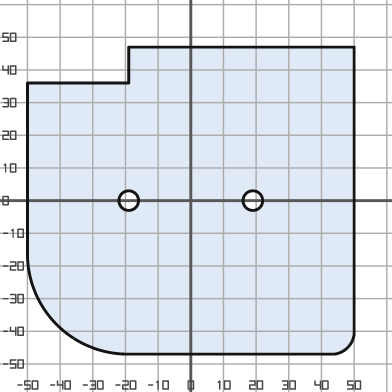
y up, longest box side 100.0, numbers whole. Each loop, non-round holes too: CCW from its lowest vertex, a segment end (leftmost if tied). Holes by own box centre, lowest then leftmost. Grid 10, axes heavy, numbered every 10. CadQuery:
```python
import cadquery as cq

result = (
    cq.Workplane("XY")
    .moveTo(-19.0, -47.0)
    .lineTo(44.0, -47.0)
    .threePointArc((48.0, -45.0), (50.0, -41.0))
    .lineTo(50.0, 47.0)
    .lineTo(-19.0, 47.0)
    .lineTo(-19.0, 36.0)
    .lineTo(-50.0, 36.0)
    .lineTo(-50.0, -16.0)
    .threePointArc((-41.0, -38.0), (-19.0, -47.0))
    .close()
    .moveTo(-19.0, 0.0)
    .circle(3.0)
    .moveTo(19.0, 0.0)
    .circle(3.0)
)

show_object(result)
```